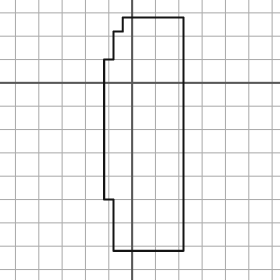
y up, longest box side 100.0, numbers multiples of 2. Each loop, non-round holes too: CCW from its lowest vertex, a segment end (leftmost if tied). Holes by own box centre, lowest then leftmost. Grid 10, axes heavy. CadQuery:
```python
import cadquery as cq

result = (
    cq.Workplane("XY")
    .moveTo(-8.0, -72.0)
    .lineTo(22.0, -72.0)
    .lineTo(22.0, 28.0)
    .lineTo(-4.0, 28.0)
    .lineTo(-4.0, 22.0)
    .lineTo(-8.0, 22.0)
    .lineTo(-8.0, 10.0)
    .lineTo(-12.0, 10.0)
    .lineTo(-12.0, -50.0)
    .lineTo(-8.0, -50.0)
    .close()
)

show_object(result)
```